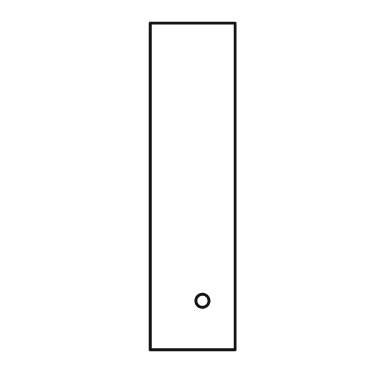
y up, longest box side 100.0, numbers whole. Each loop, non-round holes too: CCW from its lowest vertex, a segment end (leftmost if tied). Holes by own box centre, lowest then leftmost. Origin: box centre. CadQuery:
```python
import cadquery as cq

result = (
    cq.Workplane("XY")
    .moveTo(-13.0, -50.0)
    .lineTo(13.0, -50.0)
    .lineTo(13.0, 50.0)
    .lineTo(-13.0, 50.0)
    .close()
    .moveTo(3.0, -35.0)
    .circle(2.0)
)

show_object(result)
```